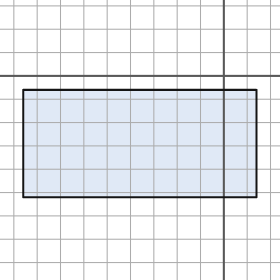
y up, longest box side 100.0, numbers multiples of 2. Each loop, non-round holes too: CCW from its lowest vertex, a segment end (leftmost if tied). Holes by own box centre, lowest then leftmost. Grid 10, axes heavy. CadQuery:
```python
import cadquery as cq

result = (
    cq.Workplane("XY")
    .moveTo(-86.0, -52.0)
    .lineTo(14.0, -52.0)
    .lineTo(14.0, -6.0)
    .lineTo(-86.0, -6.0)
    .close()
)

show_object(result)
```